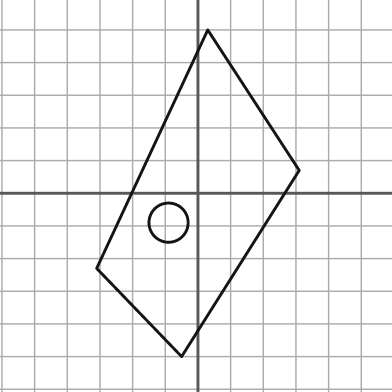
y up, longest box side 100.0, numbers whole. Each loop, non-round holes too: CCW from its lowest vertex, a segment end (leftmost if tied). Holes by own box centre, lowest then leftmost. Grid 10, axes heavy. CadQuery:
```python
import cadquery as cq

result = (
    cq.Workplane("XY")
    .moveTo(-5.0, -50.0)
    .lineTo(31.0, 7.0)
    .lineTo(3.0, 50.0)
    .lineTo(-31.0, -23.0)
    .close()
    .moveTo(-9.0, -9.0)
    .circle(6.0)
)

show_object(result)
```